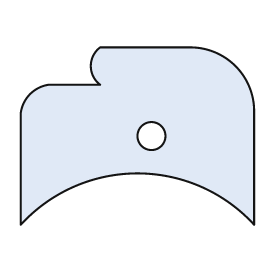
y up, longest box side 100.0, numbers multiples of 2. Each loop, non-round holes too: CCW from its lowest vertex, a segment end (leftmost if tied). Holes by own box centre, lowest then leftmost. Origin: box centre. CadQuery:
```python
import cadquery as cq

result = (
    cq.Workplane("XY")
    .moveTo(-50.0, -38.0)
    .threePointArc((0.0, -16.0), (50.0, -38.0))
    .lineTo(50.0, 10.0)
    .threePointArc((42.0, 30.0), (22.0, 38.0))
    .lineTo(-16.0, 38.0)
    .threePointArc((-20.0, 30.0), (-16.0, 22.0))
    .lineTo(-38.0, 22.0)
    .threePointArc((-46.0, 18.0), (-50.0, 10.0))
    .close()
    .moveTo(6.0, 0.0)
    .circle(6.0)
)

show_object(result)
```